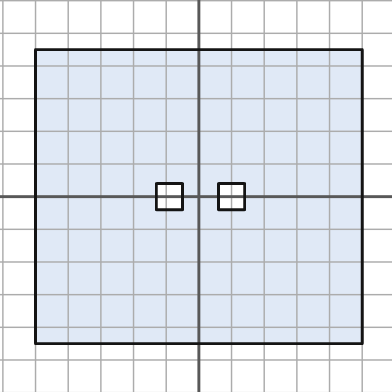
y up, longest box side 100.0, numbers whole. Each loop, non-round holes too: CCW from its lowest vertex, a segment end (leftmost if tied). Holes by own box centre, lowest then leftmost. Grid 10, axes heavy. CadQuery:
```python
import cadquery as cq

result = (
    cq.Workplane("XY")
    .moveTo(-50.0, -45.0)
    .lineTo(50.0, -45.0)
    .lineTo(50.0, 45.0)
    .lineTo(-50.0, 45.0)
    .close()
    .moveTo(-13.0, -4.0)
    .lineTo(-5.0, -4.0)
    .lineTo(-5.0, 4.0)
    .lineTo(-13.0, 4.0)
    .close()
    .moveTo(6.0, -4.0)
    .lineTo(14.0, -4.0)
    .lineTo(14.0, 4.0)
    .lineTo(6.0, 4.0)
    .close()
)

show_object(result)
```